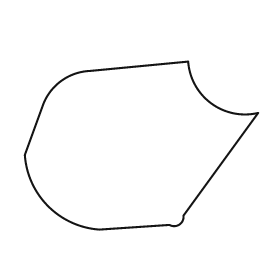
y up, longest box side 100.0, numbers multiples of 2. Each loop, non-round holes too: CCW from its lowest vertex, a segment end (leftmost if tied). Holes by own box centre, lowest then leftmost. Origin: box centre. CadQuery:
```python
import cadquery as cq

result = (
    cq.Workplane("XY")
    .moveTo(-18.0, -36.0)
    .lineTo(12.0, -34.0)
    .threePointArc((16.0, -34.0), (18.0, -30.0))
    .lineTo(50.0, 14.0)
    .threePointArc((30.0, 18.0), (20.0, 36.0))
    .lineTo(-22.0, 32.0)
    .threePointArc((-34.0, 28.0), (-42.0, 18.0))
    .lineTo(-50.0, -4.0)
    .threePointArc((-40.0, -26.0), (-18.0, -36.0))
    .close()
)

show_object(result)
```